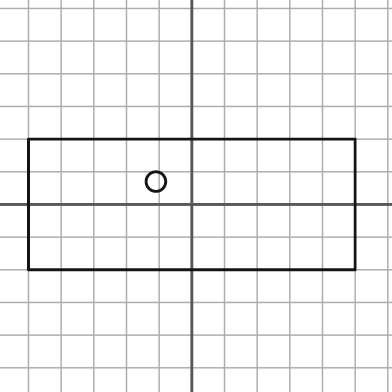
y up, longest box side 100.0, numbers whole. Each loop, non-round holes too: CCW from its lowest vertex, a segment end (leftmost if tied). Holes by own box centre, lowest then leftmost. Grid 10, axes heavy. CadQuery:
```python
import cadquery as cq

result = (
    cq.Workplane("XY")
    .moveTo(-50.0, -20.0)
    .lineTo(50.0, -20.0)
    .lineTo(50.0, 20.0)
    .lineTo(-50.0, 20.0)
    .close()
    .moveTo(-11.0, 7.0)
    .circle(3.0)
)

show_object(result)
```